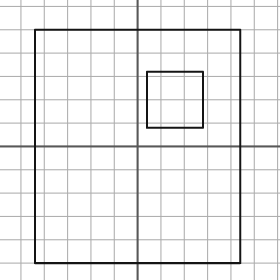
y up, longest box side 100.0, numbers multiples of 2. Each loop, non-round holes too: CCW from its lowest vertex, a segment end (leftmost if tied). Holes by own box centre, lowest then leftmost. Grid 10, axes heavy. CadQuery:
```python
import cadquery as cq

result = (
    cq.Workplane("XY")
    .moveTo(-44.0, -50.0)
    .lineTo(44.0, -50.0)
    .lineTo(44.0, 50.0)
    .lineTo(-44.0, 50.0)
    .close()
    .moveTo(4.0, 8.0)
    .lineTo(28.0, 8.0)
    .lineTo(28.0, 32.0)
    .lineTo(4.0, 32.0)
    .close()
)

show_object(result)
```